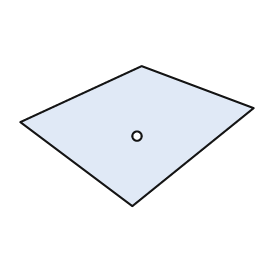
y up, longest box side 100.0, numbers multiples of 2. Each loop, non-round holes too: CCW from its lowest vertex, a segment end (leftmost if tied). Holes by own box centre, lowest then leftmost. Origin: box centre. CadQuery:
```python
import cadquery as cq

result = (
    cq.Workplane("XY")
    .moveTo(-2.0, -30.0)
    .lineTo(50.0, 12.0)
    .lineTo(2.0, 30.0)
    .lineTo(-50.0, 6.0)
    .close()
    .moveTo(0.0, 0.0)
    .circle(2.0)
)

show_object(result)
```